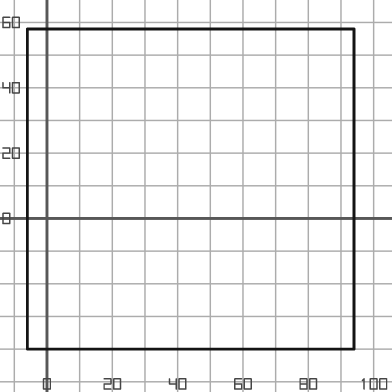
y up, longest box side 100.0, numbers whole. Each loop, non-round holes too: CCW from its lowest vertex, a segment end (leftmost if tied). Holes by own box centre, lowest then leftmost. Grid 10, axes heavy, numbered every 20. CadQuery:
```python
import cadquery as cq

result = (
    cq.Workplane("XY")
    .moveTo(-6.0, -40.0)
    .lineTo(94.0, -40.0)
    .lineTo(94.0, 58.0)
    .lineTo(-6.0, 58.0)
    .close()
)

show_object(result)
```